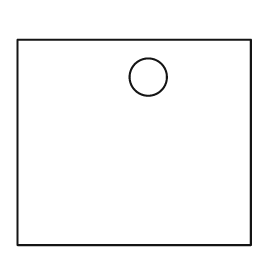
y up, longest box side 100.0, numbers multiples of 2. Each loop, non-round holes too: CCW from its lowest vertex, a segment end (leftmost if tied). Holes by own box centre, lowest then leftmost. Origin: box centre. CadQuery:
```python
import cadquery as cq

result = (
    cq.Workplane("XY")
    .moveTo(-50.0, -44.0)
    .lineTo(50.0, -44.0)
    .lineTo(50.0, 44.0)
    .lineTo(-50.0, 44.0)
    .close()
    .moveTo(6.0, 28.0)
    .circle(8.0)
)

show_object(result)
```